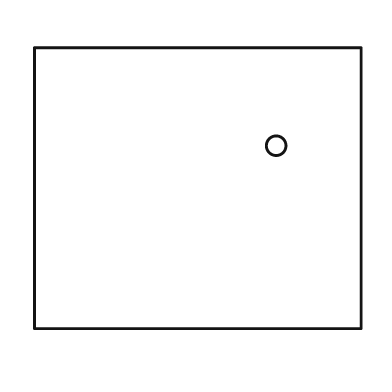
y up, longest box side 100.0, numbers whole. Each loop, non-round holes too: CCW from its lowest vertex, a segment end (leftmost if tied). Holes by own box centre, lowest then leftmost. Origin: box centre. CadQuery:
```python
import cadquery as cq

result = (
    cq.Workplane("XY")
    .moveTo(-50.0, -43.0)
    .lineTo(50.0, -43.0)
    .lineTo(50.0, 43.0)
    .lineTo(-50.0, 43.0)
    .close()
    .moveTo(24.0, 13.0)
    .circle(3.0)
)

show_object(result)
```